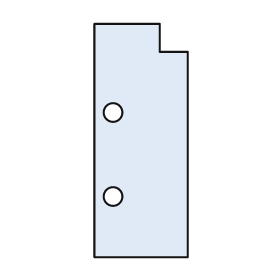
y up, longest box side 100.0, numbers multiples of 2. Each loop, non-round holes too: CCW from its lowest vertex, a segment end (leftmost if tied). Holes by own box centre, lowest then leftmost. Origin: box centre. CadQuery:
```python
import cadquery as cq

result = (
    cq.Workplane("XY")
    .moveTo(-20.0, -50.0)
    .lineTo(20.0, -50.0)
    .lineTo(20.0, 38.0)
    .lineTo(8.0, 38.0)
    .lineTo(8.0, 50.0)
    .lineTo(-20.0, 50.0)
    .close()
    .moveTo(-12.0, -24.0)
    .circle(4.0)
    .moveTo(-12.0, 12.0)
    .circle(4.0)
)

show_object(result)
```